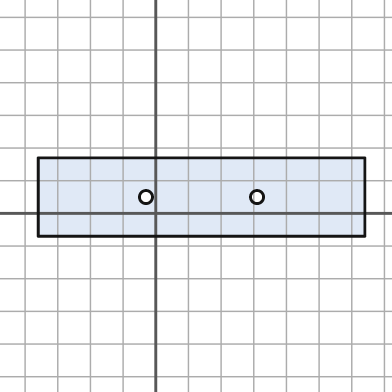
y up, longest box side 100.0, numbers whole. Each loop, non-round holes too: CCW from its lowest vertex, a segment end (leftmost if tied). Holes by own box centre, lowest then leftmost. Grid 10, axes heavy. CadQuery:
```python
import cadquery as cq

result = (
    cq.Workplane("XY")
    .moveTo(-36.0, -7.0)
    .lineTo(64.0, -7.0)
    .lineTo(64.0, 17.0)
    .lineTo(-36.0, 17.0)
    .close()
    .moveTo(-3.0, 5.0)
    .circle(2.0)
    .moveTo(31.0, 5.0)
    .circle(2.0)
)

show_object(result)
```